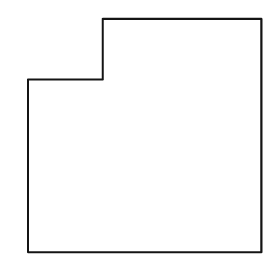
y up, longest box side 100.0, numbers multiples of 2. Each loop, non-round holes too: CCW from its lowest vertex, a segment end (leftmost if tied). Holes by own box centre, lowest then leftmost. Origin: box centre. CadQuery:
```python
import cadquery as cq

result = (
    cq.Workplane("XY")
    .moveTo(-50.0, -50.0)
    .lineTo(50.0, -50.0)
    .lineTo(50.0, 50.0)
    .lineTo(-18.0, 50.0)
    .lineTo(-18.0, 24.0)
    .lineTo(-50.0, 24.0)
    .close()
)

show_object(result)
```